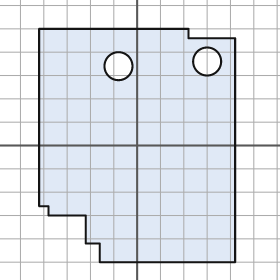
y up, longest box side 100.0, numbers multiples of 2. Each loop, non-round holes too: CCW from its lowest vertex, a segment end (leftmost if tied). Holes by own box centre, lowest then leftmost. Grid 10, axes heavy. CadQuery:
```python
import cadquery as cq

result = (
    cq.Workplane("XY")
    .moveTo(-16.0, -50.0)
    .lineTo(42.0, -50.0)
    .lineTo(42.0, 46.0)
    .lineTo(22.0, 46.0)
    .lineTo(22.0, 50.0)
    .lineTo(-42.0, 50.0)
    .lineTo(-42.0, -26.0)
    .lineTo(-38.0, -26.0)
    .lineTo(-38.0, -30.0)
    .lineTo(-22.0, -30.0)
    .lineTo(-22.0, -42.0)
    .lineTo(-16.0, -42.0)
    .close()
    .moveTo(-8.0, 34.0)
    .circle(6.0)
    .moveTo(30.0, 36.0)
    .circle(6.0)
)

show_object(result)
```